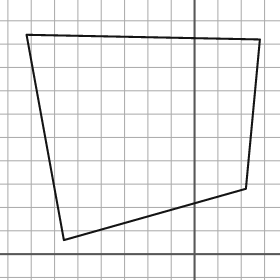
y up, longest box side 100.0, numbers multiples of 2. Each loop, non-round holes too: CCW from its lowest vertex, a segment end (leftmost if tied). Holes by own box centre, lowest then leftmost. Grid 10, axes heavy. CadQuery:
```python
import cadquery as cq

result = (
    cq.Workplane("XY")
    .moveTo(-56.0, 6.0)
    .lineTo(22.0, 28.0)
    .lineTo(28.0, 92.0)
    .lineTo(-72.0, 94.0)
    .close()
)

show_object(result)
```